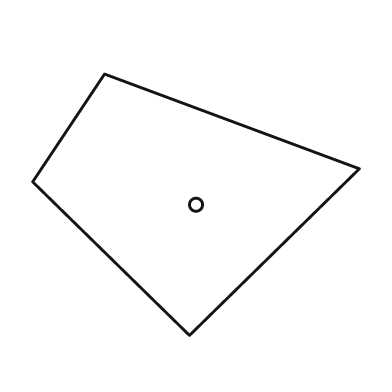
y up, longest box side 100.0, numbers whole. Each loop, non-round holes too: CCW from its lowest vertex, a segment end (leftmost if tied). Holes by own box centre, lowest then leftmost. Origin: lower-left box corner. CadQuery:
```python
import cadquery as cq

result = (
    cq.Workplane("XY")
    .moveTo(48.0, 0.0)
    .lineTo(100.0, 51.0)
    .lineTo(22.0, 80.0)
    .lineTo(0.0, 47.0)
    .close()
    .moveTo(50.0, 40.0)
    .circle(2.0)
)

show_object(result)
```